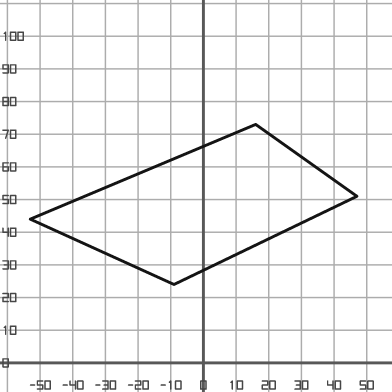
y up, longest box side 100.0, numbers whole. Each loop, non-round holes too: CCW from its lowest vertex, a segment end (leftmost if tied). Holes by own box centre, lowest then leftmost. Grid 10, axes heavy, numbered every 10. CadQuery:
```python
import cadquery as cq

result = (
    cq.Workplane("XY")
    .moveTo(-9.0, 24.0)
    .lineTo(47.0, 51.0)
    .lineTo(16.0, 73.0)
    .lineTo(-53.0, 44.0)
    .close()
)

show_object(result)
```